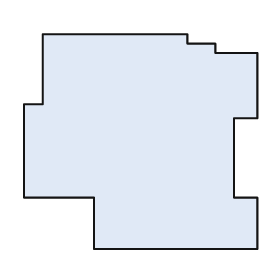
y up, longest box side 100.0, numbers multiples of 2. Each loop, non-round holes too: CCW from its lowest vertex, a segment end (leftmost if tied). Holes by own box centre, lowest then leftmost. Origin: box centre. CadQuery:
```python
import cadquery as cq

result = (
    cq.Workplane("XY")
    .moveTo(-20.0, -46.0)
    .lineTo(50.0, -46.0)
    .lineTo(50.0, -24.0)
    .lineTo(40.0, -24.0)
    .lineTo(40.0, 10.0)
    .lineTo(50.0, 10.0)
    .lineTo(50.0, 38.0)
    .lineTo(32.0, 38.0)
    .lineTo(32.0, 42.0)
    .lineTo(20.0, 42.0)
    .lineTo(20.0, 46.0)
    .lineTo(-42.0, 46.0)
    .lineTo(-42.0, 16.0)
    .lineTo(-50.0, 16.0)
    .lineTo(-50.0, -24.0)
    .lineTo(-20.0, -24.0)
    .close()
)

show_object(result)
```